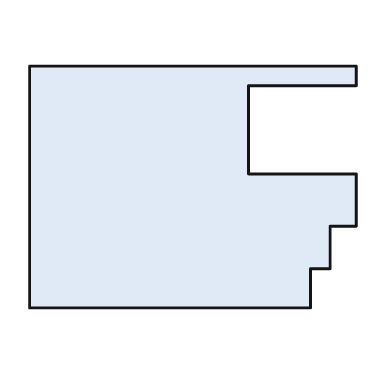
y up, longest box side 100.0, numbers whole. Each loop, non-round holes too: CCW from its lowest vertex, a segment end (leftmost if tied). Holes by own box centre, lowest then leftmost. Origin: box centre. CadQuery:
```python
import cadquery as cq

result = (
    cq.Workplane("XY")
    .moveTo(-50.0, -37.0)
    .lineTo(36.0, -37.0)
    .lineTo(36.0, -25.0)
    .lineTo(42.0, -25.0)
    .lineTo(42.0, -12.0)
    .lineTo(50.0, -12.0)
    .lineTo(50.0, 4.0)
    .lineTo(17.0, 4.0)
    .lineTo(17.0, 31.0)
    .lineTo(50.0, 31.0)
    .lineTo(50.0, 37.0)
    .lineTo(-50.0, 37.0)
    .close()
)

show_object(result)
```